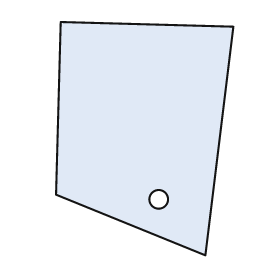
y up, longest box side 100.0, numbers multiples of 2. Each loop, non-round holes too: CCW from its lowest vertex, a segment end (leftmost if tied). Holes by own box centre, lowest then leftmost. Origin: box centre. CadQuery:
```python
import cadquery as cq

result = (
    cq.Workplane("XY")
    .moveTo(26.0, -50.0)
    .lineTo(38.0, 48.0)
    .lineTo(-36.0, 50.0)
    .lineTo(-38.0, -24.0)
    .close()
    .moveTo(6.0, -26.0)
    .circle(4.0)
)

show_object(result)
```